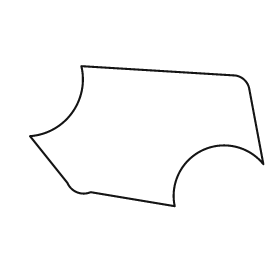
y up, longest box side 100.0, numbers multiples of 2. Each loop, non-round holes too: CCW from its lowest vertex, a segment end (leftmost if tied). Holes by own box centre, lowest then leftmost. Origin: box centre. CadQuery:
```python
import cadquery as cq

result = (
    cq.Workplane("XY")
    .moveTo(12.0, -30.0)
    .threePointArc((24.0, -6.0), (50.0, -12.0))
    .lineTo(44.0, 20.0)
    .threePointArc((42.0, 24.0), (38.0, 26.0))
    .lineTo(-28.0, 30.0)
    .threePointArc((-32.0, 10.0), (-50.0, 0.0))
    .lineTo(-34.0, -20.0)
    .threePointArc((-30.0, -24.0), (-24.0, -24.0))
    .close()
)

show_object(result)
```